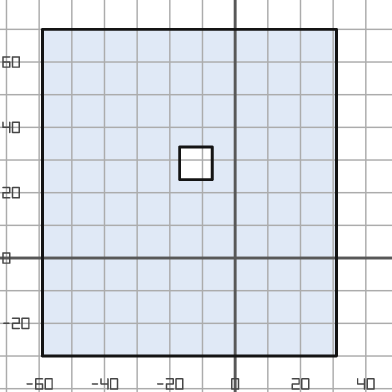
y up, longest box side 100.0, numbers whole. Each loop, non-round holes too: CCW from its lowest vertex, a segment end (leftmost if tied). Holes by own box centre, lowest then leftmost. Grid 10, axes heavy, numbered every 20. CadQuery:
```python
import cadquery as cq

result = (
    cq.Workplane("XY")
    .moveTo(-59.0, -30.0)
    .lineTo(31.0, -30.0)
    .lineTo(31.0, 70.0)
    .lineTo(-59.0, 70.0)
    .close()
    .moveTo(-17.0, 24.0)
    .lineTo(-7.0, 24.0)
    .lineTo(-7.0, 34.0)
    .lineTo(-17.0, 34.0)
    .close()
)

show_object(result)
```